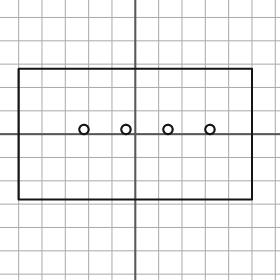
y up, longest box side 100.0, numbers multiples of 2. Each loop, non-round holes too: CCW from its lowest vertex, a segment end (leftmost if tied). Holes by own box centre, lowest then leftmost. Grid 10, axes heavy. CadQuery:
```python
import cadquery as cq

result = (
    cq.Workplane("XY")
    .moveTo(-50.0, -28.0)
    .lineTo(50.0, -28.0)
    .lineTo(50.0, 28.0)
    .lineTo(-50.0, 28.0)
    .close()
    .moveTo(-22.0, 2.0)
    .circle(2.0)
    .moveTo(-4.0, 2.0)
    .circle(2.0)
    .moveTo(14.0, 2.0)
    .circle(2.0)
    .moveTo(32.0, 2.0)
    .circle(2.0)
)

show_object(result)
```